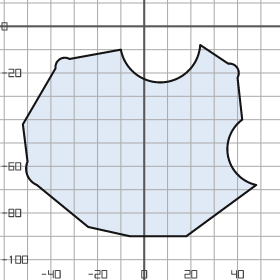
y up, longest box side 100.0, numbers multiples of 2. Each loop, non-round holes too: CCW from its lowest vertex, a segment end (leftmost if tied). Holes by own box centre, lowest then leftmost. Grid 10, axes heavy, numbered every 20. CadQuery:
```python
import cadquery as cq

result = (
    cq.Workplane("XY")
    .moveTo(-6.0, -90.0)
    .lineTo(18.0, -90.0)
    .lineTo(48.0, -68.0)
    .threePointArc((36.0, -56.0), (42.0, -40.0))
    .lineTo(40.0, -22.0)
    .threePointArc((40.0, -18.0), (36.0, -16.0))
    .lineTo(24.0, -8.0)
    .threePointArc((8.0, -24.0), (-10.0, -10.0))
    .lineTo(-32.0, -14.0)
    .threePointArc((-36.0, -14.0), (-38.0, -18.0))
    .lineTo(-52.0, -42.0)
    .lineTo(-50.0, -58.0)
    .threePointArc((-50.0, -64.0), (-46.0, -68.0))
    .lineTo(-24.0, -86.0)
    .close()
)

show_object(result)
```